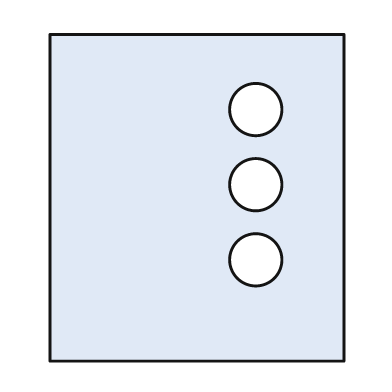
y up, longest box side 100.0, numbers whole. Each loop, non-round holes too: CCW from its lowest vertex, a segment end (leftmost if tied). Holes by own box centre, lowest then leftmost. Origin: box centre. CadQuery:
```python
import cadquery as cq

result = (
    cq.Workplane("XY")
    .moveTo(-45.0, -50.0)
    .lineTo(45.0, -50.0)
    .lineTo(45.0, 50.0)
    .lineTo(-45.0, 50.0)
    .close()
    .moveTo(18.0, -19.0)
    .circle(8.0)
    .moveTo(18.0, 4.0)
    .circle(8.0)
    .moveTo(18.0, 27.0)
    .circle(8.0)
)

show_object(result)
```